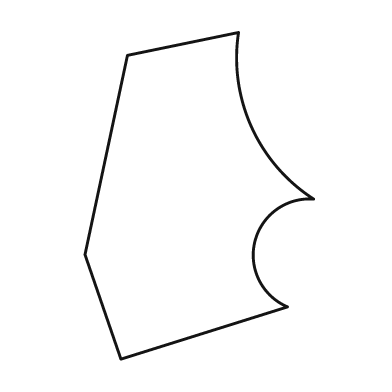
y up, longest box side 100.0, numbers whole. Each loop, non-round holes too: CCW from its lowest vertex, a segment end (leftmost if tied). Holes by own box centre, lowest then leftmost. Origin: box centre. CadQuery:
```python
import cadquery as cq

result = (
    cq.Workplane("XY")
    .moveTo(-24.0, -50.0)
    .lineTo(27.0, -34.0)
    .threePointArc((17.0, -14.0), (35.0, -1.0))
    .threePointArc((16.0, 21.0), (12.0, 50.0))
    .lineTo(-22.0, 43.0)
    .lineTo(-35.0, -18.0)
    .close()
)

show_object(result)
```